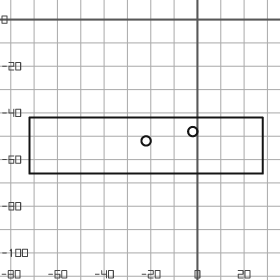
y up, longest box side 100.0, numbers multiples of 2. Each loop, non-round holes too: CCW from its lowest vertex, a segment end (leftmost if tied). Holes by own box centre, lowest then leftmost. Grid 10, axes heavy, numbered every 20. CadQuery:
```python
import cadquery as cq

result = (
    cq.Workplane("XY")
    .moveTo(-72.0, -66.0)
    .lineTo(28.0, -66.0)
    .lineTo(28.0, -42.0)
    .lineTo(-72.0, -42.0)
    .close()
    .moveTo(-22.0, -52.0)
    .circle(2.0)
    .moveTo(-2.0, -48.0)
    .circle(2.0)
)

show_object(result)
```